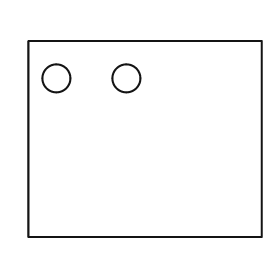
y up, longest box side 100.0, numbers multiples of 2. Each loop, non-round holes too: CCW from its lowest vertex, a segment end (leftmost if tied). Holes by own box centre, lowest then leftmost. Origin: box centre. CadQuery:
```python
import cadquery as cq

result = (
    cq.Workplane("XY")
    .moveTo(-50.0, -42.0)
    .lineTo(50.0, -42.0)
    .lineTo(50.0, 42.0)
    .lineTo(-50.0, 42.0)
    .close()
    .moveTo(-38.0, 26.0)
    .circle(6.0)
    .moveTo(-8.0, 26.0)
    .circle(6.0)
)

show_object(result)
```